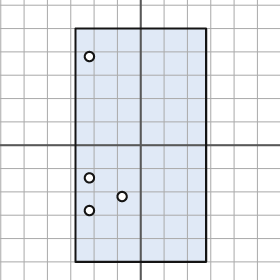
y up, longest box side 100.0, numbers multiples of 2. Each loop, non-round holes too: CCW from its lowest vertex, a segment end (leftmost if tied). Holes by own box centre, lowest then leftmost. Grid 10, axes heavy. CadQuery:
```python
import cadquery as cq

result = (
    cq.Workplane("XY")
    .moveTo(-28.0, -50.0)
    .lineTo(28.0, -50.0)
    .lineTo(28.0, 50.0)
    .lineTo(-28.0, 50.0)
    .close()
    .moveTo(-22.0, -28.0)
    .circle(2.0)
    .moveTo(-8.0, -22.0)
    .circle(2.0)
    .moveTo(-22.0, -14.0)
    .circle(2.0)
    .moveTo(-22.0, 38.0)
    .circle(2.0)
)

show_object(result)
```